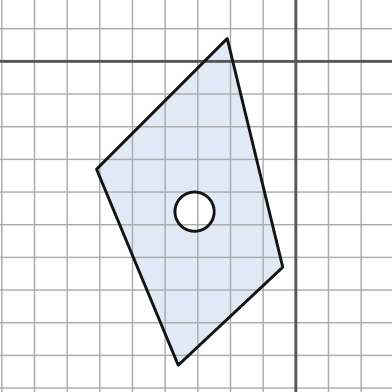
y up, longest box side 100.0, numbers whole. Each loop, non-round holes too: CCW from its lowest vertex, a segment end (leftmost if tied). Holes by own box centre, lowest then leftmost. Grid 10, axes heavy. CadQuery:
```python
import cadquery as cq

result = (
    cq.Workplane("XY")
    .moveTo(-36.0, -93.0)
    .lineTo(-4.0, -63.0)
    .lineTo(-21.0, 7.0)
    .lineTo(-61.0, -33.0)
    .close()
    .moveTo(-31.0, -46.0)
    .circle(6.0)
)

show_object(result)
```